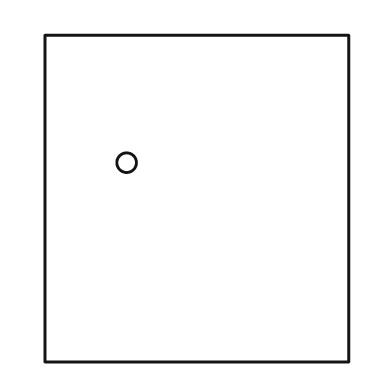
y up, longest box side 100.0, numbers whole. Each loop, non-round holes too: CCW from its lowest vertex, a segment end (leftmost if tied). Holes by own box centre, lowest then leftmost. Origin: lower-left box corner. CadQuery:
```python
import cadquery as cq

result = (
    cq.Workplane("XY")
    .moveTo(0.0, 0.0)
    .lineTo(93.0, 0.0)
    .lineTo(93.0, 100.0)
    .lineTo(0.0, 100.0)
    .close()
    .moveTo(25.0, 61.0)
    .circle(3.0)
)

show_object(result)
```